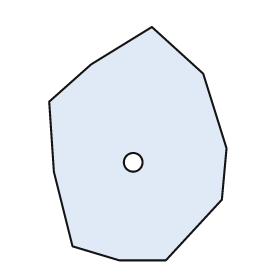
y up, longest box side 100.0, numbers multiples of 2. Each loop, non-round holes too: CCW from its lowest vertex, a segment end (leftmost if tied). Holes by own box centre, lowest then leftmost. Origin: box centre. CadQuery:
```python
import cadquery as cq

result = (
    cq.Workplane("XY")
    .moveTo(-8.0, -50.0)
    .lineTo(12.0, -50.0)
    .lineTo(36.0, -24.0)
    .lineTo(38.0, -2.0)
    .lineTo(28.0, 30.0)
    .lineTo(6.0, 50.0)
    .lineTo(-20.0, 34.0)
    .lineTo(-38.0, 18.0)
    .lineTo(-36.0, -12.0)
    .lineTo(-28.0, -44.0)
    .close()
    .moveTo(-2.0, -8.0)
    .circle(4.0)
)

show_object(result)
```